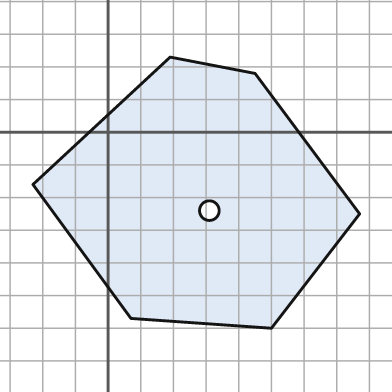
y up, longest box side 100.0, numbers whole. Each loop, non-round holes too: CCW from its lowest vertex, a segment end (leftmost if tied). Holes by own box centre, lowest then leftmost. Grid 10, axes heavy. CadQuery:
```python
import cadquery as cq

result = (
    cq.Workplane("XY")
    .moveTo(50.0, -60.0)
    .lineTo(77.0, -25.0)
    .lineTo(45.0, 18.0)
    .lineTo(19.0, 23.0)
    .lineTo(-23.0, -16.0)
    .lineTo(7.0, -57.0)
    .close()
    .moveTo(31.0, -24.0)
    .circle(3.0)
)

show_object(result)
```